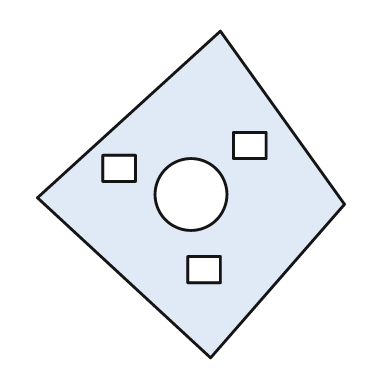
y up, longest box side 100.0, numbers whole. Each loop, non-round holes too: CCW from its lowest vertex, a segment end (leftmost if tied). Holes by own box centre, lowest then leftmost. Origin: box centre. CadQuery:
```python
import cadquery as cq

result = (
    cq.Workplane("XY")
    .moveTo(6.0, -50.0)
    .lineTo(47.0, -3.0)
    .lineTo(9.0, 50.0)
    .lineTo(-47.0, -1.0)
    .close()
    .moveTo(-1.0, -27.0)
    .lineTo(9.0, -27.0)
    .lineTo(9.0, -19.0)
    .lineTo(-1.0, -19.0)
    .close()
    .moveTo(0.0, 0.0)
    .circle(11.0)
    .moveTo(-27.0, 4.0)
    .lineTo(-17.0, 4.0)
    .lineTo(-17.0, 12.0)
    .lineTo(-27.0, 12.0)
    .close()
    .moveTo(13.0, 11.0)
    .lineTo(23.0, 11.0)
    .lineTo(23.0, 19.0)
    .lineTo(13.0, 19.0)
    .close()
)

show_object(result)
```